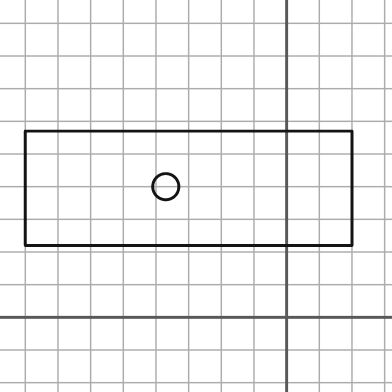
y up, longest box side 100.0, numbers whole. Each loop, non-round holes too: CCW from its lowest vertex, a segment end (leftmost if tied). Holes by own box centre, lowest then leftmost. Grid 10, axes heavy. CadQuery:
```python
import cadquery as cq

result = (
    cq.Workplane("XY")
    .moveTo(-80.0, 22.0)
    .lineTo(20.0, 22.0)
    .lineTo(20.0, 57.0)
    .lineTo(-80.0, 57.0)
    .close()
    .moveTo(-37.0, 40.0)
    .circle(4.0)
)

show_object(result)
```